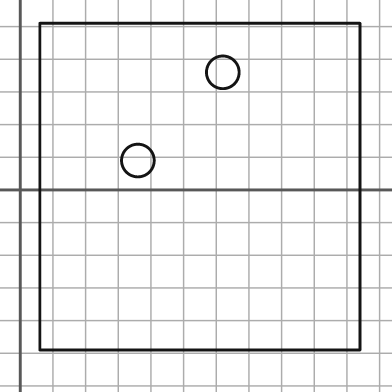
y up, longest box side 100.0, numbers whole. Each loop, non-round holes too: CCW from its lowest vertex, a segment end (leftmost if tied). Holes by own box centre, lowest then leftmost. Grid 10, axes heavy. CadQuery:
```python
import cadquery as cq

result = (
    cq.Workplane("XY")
    .moveTo(6.0, -49.0)
    .lineTo(104.0, -49.0)
    .lineTo(104.0, 51.0)
    .lineTo(6.0, 51.0)
    .close()
    .moveTo(36.0, 9.0)
    .circle(5.0)
    .moveTo(62.0, 36.0)
    .circle(5.0)
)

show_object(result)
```